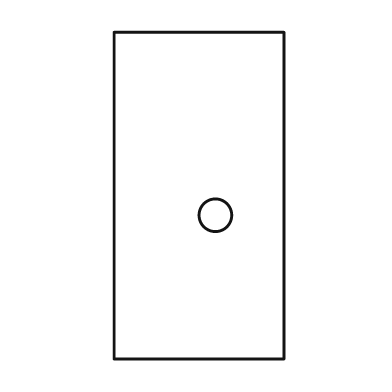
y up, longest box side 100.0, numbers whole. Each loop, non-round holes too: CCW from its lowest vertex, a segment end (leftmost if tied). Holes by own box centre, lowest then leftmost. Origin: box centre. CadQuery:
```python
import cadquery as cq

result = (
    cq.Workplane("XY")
    .moveTo(-26.0, -50.0)
    .lineTo(26.0, -50.0)
    .lineTo(26.0, 50.0)
    .lineTo(-26.0, 50.0)
    .close()
    .moveTo(5.0, -6.0)
    .circle(5.0)
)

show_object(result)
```